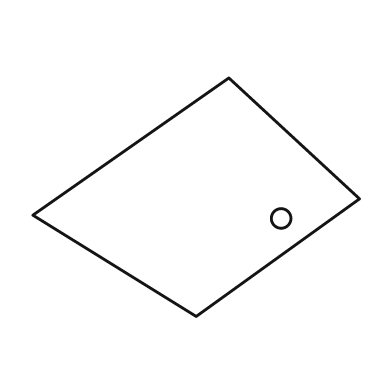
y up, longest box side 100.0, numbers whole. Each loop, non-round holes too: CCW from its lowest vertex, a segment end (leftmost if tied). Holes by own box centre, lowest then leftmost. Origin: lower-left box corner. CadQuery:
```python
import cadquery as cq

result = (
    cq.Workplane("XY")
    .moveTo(50.0, 0.0)
    .lineTo(100.0, 36.0)
    .lineTo(60.0, 73.0)
    .lineTo(0.0, 31.0)
    .close()
    .moveTo(76.0, 30.0)
    .circle(3.0)
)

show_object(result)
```